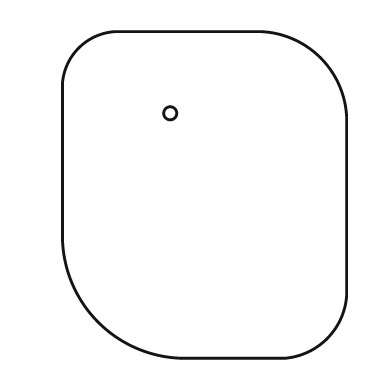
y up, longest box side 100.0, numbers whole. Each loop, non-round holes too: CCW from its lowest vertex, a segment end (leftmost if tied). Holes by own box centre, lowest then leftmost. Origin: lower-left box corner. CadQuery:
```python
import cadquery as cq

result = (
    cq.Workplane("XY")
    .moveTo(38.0, 0.0)
    .lineTo(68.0, 0.0)
    .threePointArc((81.0, 6.0), (87.0, 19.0))
    .lineTo(87.0, 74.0)
    .threePointArc((79.0, 92.0), (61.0, 100.0))
    .lineTo(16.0, 100.0)
    .threePointArc((5.0, 95.0), (0.0, 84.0))
    .lineTo(0.0, 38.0)
    .threePointArc((11.0, 11.0), (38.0, 0.0))
    .close()
    .moveTo(33.0, 75.0)
    .circle(2.0)
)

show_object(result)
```